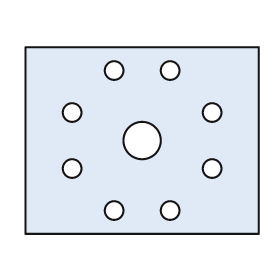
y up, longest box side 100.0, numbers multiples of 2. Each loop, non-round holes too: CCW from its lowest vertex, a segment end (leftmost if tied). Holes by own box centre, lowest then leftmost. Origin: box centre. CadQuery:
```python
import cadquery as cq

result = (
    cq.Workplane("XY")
    .moveTo(-50.0, -40.0)
    .lineTo(50.0, -40.0)
    .lineTo(50.0, 40.0)
    .lineTo(-50.0, 40.0)
    .close()
    .moveTo(-12.0, -30.0)
    .circle(4.0)
    .moveTo(12.0, -30.0)
    .circle(4.0)
    .moveTo(-30.0, -12.0)
    .circle(4.0)
    .moveTo(30.0, -12.0)
    .circle(4.0)
    .moveTo(0.0, 0.0)
    .circle(8.0)
    .moveTo(-30.0, 12.0)
    .circle(4.0)
    .moveTo(30.0, 12.0)
    .circle(4.0)
    .moveTo(-12.0, 30.0)
    .circle(4.0)
    .moveTo(12.0, 30.0)
    .circle(4.0)
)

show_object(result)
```